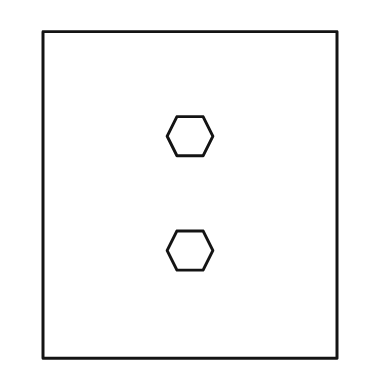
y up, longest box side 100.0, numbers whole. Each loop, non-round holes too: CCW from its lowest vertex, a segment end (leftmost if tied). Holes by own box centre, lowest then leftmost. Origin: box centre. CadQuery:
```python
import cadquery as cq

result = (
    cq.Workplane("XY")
    .moveTo(-45.0, -50.0)
    .lineTo(45.0, -50.0)
    .lineTo(45.0, 50.0)
    .lineTo(-45.0, 50.0)
    .close()
    .moveTo(-4.0, -23.0)
    .lineTo(4.0, -23.0)
    .lineTo(7.0, -17.0)
    .lineTo(4.0, -11.0)
    .lineTo(-4.0, -11.0)
    .lineTo(-7.0, -17.0)
    .close()
    .moveTo(-4.0, 12.0)
    .lineTo(4.0, 12.0)
    .lineTo(7.0, 18.0)
    .lineTo(4.0, 24.0)
    .lineTo(-4.0, 24.0)
    .lineTo(-7.0, 18.0)
    .close()
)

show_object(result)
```